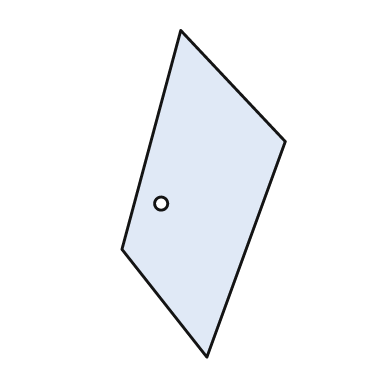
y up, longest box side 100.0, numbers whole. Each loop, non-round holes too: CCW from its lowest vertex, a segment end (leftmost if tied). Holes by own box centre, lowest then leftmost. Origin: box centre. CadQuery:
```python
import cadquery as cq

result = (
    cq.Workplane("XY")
    .moveTo(1.0, -50.0)
    .lineTo(25.0, 16.0)
    .lineTo(-7.0, 50.0)
    .lineTo(-25.0, -17.0)
    .close()
    .moveTo(-13.0, -3.0)
    .circle(2.0)
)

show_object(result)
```